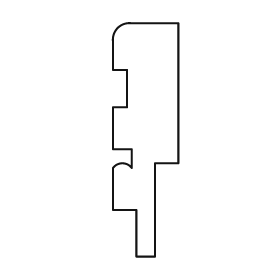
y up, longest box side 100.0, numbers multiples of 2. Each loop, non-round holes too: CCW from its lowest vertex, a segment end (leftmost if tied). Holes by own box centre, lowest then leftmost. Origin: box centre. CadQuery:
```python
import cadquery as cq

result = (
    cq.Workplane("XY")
    .moveTo(-4.0, -50.0)
    .lineTo(4.0, -50.0)
    .lineTo(4.0, -10.0)
    .lineTo(14.0, -10.0)
    .lineTo(14.0, 50.0)
    .lineTo(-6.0, 50.0)
    .threePointArc((-12.0, 48.0), (-14.0, 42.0))
    .lineTo(-14.0, 30.0)
    .lineTo(-8.0, 30.0)
    .lineTo(-8.0, 14.0)
    .lineTo(-14.0, 14.0)
    .lineTo(-14.0, -4.0)
    .lineTo(-6.0, -4.0)
    .lineTo(-6.0, -12.0)
    .threePointArc((-10.0, -10.0), (-14.0, -12.0))
    .lineTo(-14.0, -30.0)
    .lineTo(-4.0, -30.0)
    .close()
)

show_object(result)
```